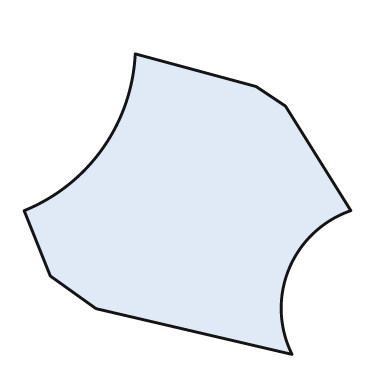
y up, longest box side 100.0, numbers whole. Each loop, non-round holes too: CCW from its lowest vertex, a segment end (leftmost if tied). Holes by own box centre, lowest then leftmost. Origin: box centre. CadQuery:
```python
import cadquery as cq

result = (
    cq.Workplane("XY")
    .moveTo(32.0, -46.0)
    .threePointArc((31.0, -20.0), (50.0, -2.0))
    .lineTo(30.0, 30.0)
    .lineTo(21.0, 36.0)
    .lineTo(-16.0, 46.0)
    .threePointArc((-26.0, 17.0), (-50.0, -2.0))
    .lineTo(-42.0, -22.0)
    .lineTo(-28.0, -32.0)
    .close()
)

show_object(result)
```